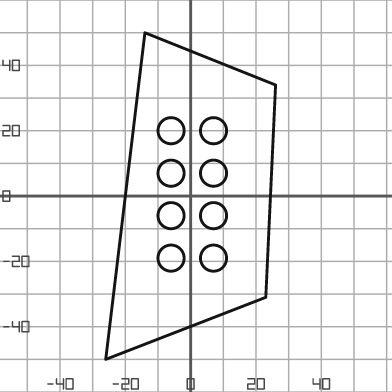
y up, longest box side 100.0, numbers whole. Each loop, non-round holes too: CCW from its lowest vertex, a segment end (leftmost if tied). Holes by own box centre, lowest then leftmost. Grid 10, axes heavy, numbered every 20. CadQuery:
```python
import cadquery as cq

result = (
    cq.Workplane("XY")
    .moveTo(-26.0, -50.0)
    .lineTo(23.0, -31.0)
    .lineTo(26.0, 34.0)
    .lineTo(-14.0, 50.0)
    .close()
    .moveTo(-6.0, -19.0)
    .circle(4.0)
    .moveTo(7.0, -19.0)
    .circle(4.0)
    .moveTo(-6.0, -6.0)
    .circle(4.0)
    .moveTo(7.0, -6.0)
    .circle(4.0)
    .moveTo(-6.0, 7.0)
    .circle(4.0)
    .moveTo(7.0, 7.0)
    .circle(4.0)
    .moveTo(-6.0, 20.0)
    .circle(4.0)
    .moveTo(7.0, 20.0)
    .circle(4.0)
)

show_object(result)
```